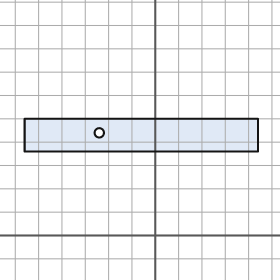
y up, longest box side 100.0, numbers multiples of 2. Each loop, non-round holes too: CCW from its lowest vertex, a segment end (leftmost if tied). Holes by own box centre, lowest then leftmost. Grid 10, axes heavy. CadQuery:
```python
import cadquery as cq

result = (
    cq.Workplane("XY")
    .moveTo(-56.0, 36.0)
    .lineTo(44.0, 36.0)
    .lineTo(44.0, 50.0)
    .lineTo(-56.0, 50.0)
    .close()
    .moveTo(-24.0, 44.0)
    .circle(2.0)
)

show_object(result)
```